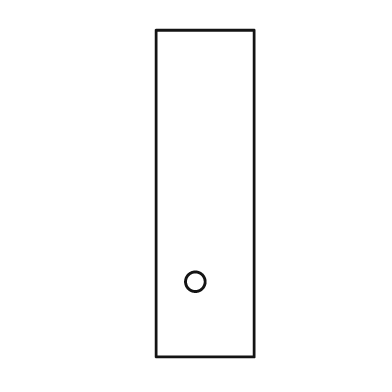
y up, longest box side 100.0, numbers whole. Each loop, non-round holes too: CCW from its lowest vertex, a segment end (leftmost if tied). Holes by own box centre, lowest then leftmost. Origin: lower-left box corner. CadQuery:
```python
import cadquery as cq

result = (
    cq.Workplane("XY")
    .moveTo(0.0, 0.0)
    .lineTo(30.0, 0.0)
    .lineTo(30.0, 100.0)
    .lineTo(0.0, 100.0)
    .close()
    .moveTo(12.0, 23.0)
    .circle(3.0)
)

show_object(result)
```